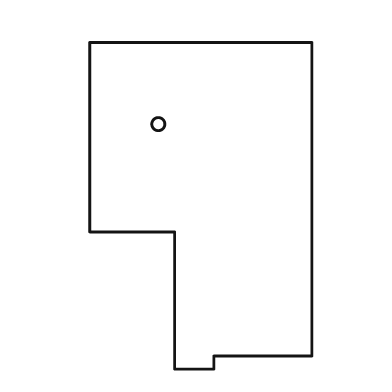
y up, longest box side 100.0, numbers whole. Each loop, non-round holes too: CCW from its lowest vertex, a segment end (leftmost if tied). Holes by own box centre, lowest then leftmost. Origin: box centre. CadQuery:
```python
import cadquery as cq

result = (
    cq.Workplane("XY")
    .moveTo(-8.0, -50.0)
    .lineTo(4.0, -50.0)
    .lineTo(4.0, -46.0)
    .lineTo(34.0, -46.0)
    .lineTo(34.0, 50.0)
    .lineTo(-34.0, 50.0)
    .lineTo(-34.0, -8.0)
    .lineTo(-8.0, -8.0)
    .close()
    .moveTo(-13.0, 25.0)
    .circle(2.0)
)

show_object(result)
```